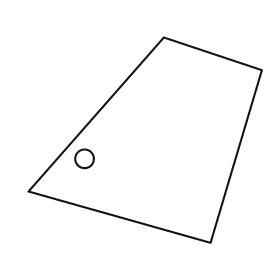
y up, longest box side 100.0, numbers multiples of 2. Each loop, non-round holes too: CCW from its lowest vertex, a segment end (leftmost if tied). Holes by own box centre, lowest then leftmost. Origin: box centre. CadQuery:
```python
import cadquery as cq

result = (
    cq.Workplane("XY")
    .moveTo(28.0, -44.0)
    .lineTo(50.0, 30.0)
    .lineTo(8.0, 44.0)
    .lineTo(-50.0, -22.0)
    .close()
    .moveTo(-26.0, -8.0)
    .circle(4.0)
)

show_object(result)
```